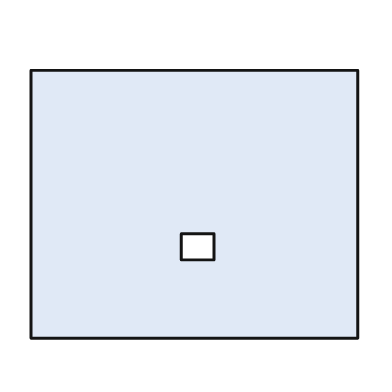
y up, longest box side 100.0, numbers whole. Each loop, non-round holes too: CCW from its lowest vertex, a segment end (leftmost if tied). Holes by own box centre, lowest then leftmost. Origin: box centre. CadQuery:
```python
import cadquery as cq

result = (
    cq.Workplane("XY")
    .moveTo(-50.0, -41.0)
    .lineTo(50.0, -41.0)
    .lineTo(50.0, 41.0)
    .lineTo(-50.0, 41.0)
    .close()
    .moveTo(-4.0, -17.0)
    .lineTo(6.0, -17.0)
    .lineTo(6.0, -9.0)
    .lineTo(-4.0, -9.0)
    .close()
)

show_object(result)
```